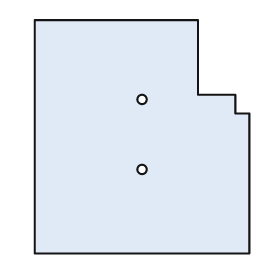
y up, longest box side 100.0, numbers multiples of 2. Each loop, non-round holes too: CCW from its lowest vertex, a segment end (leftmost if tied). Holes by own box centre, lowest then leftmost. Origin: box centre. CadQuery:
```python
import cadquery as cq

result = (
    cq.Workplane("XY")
    .moveTo(-46.0, -50.0)
    .lineTo(46.0, -50.0)
    .lineTo(46.0, 10.0)
    .lineTo(40.0, 10.0)
    .lineTo(40.0, 18.0)
    .lineTo(24.0, 18.0)
    .lineTo(24.0, 50.0)
    .lineTo(-46.0, 50.0)
    .close()
    .moveTo(0.0, -14.0)
    .circle(2.0)
    .moveTo(0.0, 16.0)
    .circle(2.0)
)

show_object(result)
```